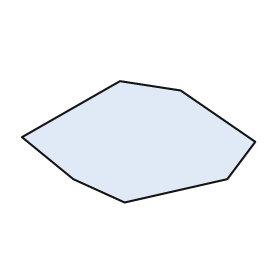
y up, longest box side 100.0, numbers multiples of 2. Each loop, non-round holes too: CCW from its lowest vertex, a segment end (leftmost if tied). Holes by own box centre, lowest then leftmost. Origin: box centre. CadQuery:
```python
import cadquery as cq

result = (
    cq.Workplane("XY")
    .moveTo(-6.0, -26.0)
    .lineTo(38.0, -16.0)
    .lineTo(50.0, 0.0)
    .lineTo(18.0, 22.0)
    .lineTo(-8.0, 26.0)
    .lineTo(-50.0, 2.0)
    .lineTo(-28.0, -16.0)
    .close()
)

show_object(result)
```